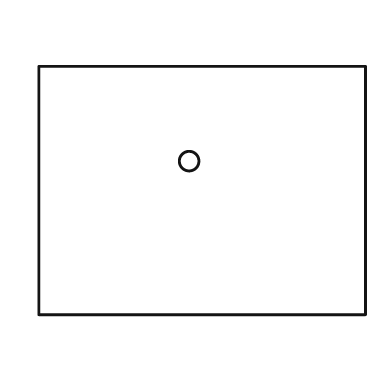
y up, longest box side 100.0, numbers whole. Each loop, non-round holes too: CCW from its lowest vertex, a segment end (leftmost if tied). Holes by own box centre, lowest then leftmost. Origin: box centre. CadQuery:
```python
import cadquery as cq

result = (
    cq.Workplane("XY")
    .moveTo(-50.0, -38.0)
    .lineTo(50.0, -38.0)
    .lineTo(50.0, 38.0)
    .lineTo(-50.0, 38.0)
    .close()
    .moveTo(-4.0, 9.0)
    .circle(3.0)
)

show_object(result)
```